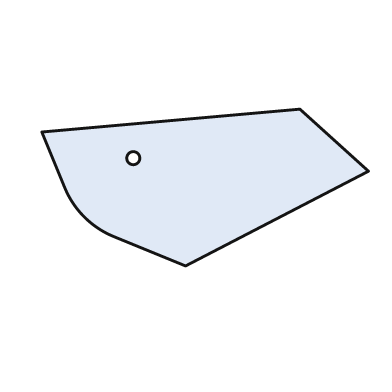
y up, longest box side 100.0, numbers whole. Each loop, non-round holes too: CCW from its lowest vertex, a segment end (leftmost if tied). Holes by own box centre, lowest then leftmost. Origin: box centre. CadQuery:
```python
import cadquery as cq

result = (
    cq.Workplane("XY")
    .moveTo(-6.0, -24.0)
    .lineTo(50.0, 5.0)
    .lineTo(29.0, 24.0)
    .lineTo(-50.0, 17.0)
    .lineTo(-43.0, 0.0)
    .threePointArc((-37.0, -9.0), (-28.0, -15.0))
    .close()
    .moveTo(-22.0, 9.0)
    .circle(2.0)
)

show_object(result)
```